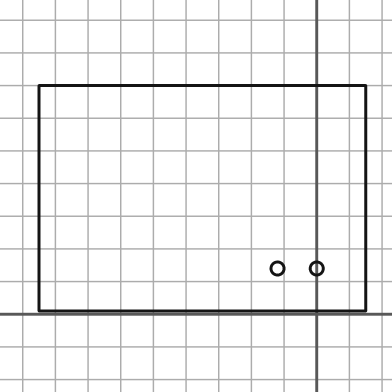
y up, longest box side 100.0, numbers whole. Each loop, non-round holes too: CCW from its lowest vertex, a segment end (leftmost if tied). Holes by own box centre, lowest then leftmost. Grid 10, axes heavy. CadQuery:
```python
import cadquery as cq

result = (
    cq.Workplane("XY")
    .moveTo(-85.0, 1.0)
    .lineTo(15.0, 1.0)
    .lineTo(15.0, 70.0)
    .lineTo(-85.0, 70.0)
    .close()
    .moveTo(-12.0, 14.0)
    .circle(2.0)
    .moveTo(0.0, 14.0)
    .circle(2.0)
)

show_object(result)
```